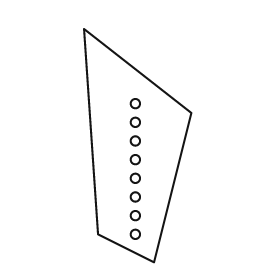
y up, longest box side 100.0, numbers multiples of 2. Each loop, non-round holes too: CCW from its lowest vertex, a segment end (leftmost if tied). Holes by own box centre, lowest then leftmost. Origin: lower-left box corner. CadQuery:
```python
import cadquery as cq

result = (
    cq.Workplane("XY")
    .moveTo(30.0, 0.0)
    .lineTo(46.0, 64.0)
    .lineTo(0.0, 100.0)
    .lineTo(6.0, 12.0)
    .close()
    .moveTo(22.0, 12.0)
    .circle(2.0)
    .moveTo(22.0, 20.0)
    .circle(2.0)
    .moveTo(22.0, 28.0)
    .circle(2.0)
    .moveTo(22.0, 36.0)
    .circle(2.0)
    .moveTo(22.0, 44.0)
    .circle(2.0)
    .moveTo(22.0, 52.0)
    .circle(2.0)
    .moveTo(22.0, 60.0)
    .circle(2.0)
    .moveTo(22.0, 68.0)
    .circle(2.0)
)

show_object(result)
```